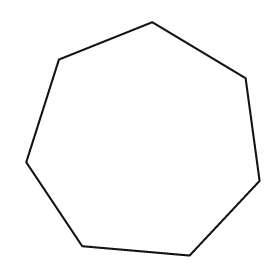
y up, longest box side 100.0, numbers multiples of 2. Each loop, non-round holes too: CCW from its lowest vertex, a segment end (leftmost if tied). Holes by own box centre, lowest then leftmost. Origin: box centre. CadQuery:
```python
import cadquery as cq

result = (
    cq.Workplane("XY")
    .moveTo(20.0, -50.0)
    .lineTo(50.0, -18.0)
    .lineTo(44.0, 26.0)
    .lineTo(4.0, 50.0)
    .lineTo(-36.0, 34.0)
    .lineTo(-50.0, -10.0)
    .lineTo(-26.0, -46.0)
    .close()
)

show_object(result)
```